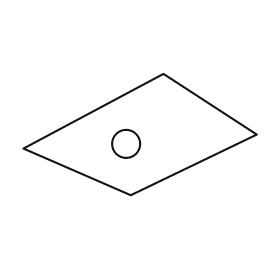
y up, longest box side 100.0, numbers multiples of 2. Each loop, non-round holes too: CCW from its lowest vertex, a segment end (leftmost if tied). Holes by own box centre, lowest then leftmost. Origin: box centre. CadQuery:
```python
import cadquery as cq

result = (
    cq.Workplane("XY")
    .moveTo(-4.0, -26.0)
    .lineTo(50.0, 0.0)
    .lineTo(10.0, 26.0)
    .lineTo(-50.0, -6.0)
    .close()
    .moveTo(-6.0, -4.0)
    .circle(6.0)
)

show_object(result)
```